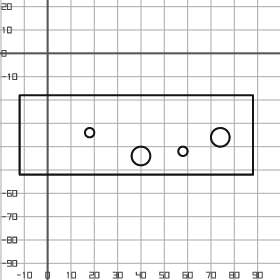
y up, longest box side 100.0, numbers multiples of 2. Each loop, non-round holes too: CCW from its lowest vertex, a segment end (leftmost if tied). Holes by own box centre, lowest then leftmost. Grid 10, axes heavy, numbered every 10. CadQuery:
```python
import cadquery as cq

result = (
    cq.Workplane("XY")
    .moveTo(-12.0, -52.0)
    .lineTo(88.0, -52.0)
    .lineTo(88.0, -18.0)
    .lineTo(-12.0, -18.0)
    .close()
    .moveTo(40.0, -44.0)
    .circle(4.0)
    .moveTo(58.0, -42.0)
    .circle(2.0)
    .moveTo(74.0, -36.0)
    .circle(4.0)
    .moveTo(18.0, -34.0)
    .circle(2.0)
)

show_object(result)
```